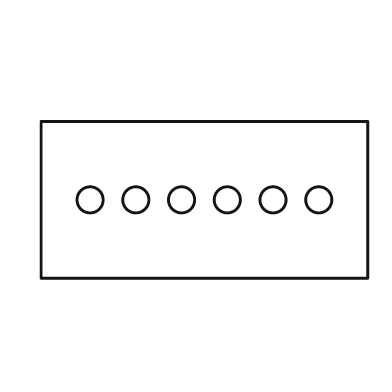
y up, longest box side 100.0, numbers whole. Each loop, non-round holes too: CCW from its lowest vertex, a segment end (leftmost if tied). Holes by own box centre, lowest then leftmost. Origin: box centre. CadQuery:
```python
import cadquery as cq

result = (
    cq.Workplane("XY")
    .moveTo(-50.0, -24.0)
    .lineTo(50.0, -24.0)
    .lineTo(50.0, 24.0)
    .lineTo(-50.0, 24.0)
    .close()
    .moveTo(-35.0, 0.0)
    .circle(4.0)
    .moveTo(-21.0, 0.0)
    .circle(4.0)
    .moveTo(-7.0, 0.0)
    .circle(4.0)
    .moveTo(7.0, 0.0)
    .circle(4.0)
    .moveTo(21.0, 0.0)
    .circle(4.0)
    .moveTo(35.0, 0.0)
    .circle(4.0)
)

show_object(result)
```